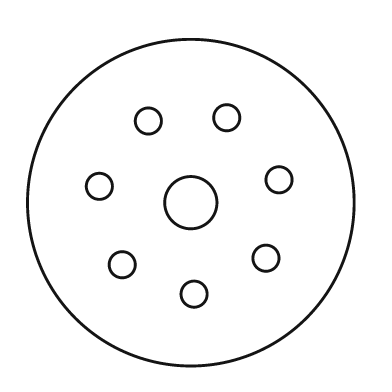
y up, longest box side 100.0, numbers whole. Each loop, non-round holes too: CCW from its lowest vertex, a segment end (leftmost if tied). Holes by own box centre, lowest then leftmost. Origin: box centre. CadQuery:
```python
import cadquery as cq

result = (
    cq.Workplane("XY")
    .moveTo(0.0, 0.0)
    .circle(50.0)
    .moveTo(1.0, -28.0)
    .circle(4.0)
    .moveTo(-21.0, -19.0)
    .circle(4.0)
    .moveTo(23.0, -17.0)
    .circle(4.0)
    .moveTo(0.0, 0.0)
    .circle(8.0)
    .moveTo(-28.0, 5.0)
    .circle(4.0)
    .moveTo(27.0, 7.0)
    .circle(4.0)
    .moveTo(-13.0, 25.0)
    .circle(4.0)
    .moveTo(11.0, 26.0)
    .circle(4.0)
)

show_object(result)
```